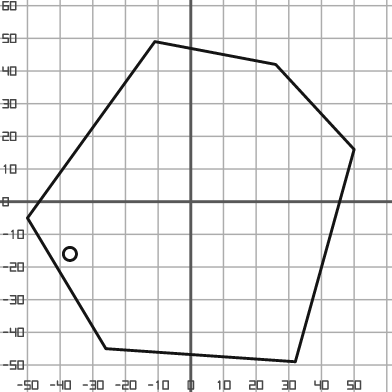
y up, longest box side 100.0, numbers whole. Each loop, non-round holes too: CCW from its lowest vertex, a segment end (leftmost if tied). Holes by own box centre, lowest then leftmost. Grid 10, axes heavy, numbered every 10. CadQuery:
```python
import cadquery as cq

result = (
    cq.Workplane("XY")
    .moveTo(32.0, -49.0)
    .lineTo(50.0, 16.0)
    .lineTo(26.0, 42.0)
    .lineTo(-11.0, 49.0)
    .lineTo(-50.0, -5.0)
    .lineTo(-26.0, -45.0)
    .close()
    .moveTo(-37.0, -16.0)
    .circle(2.0)
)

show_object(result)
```